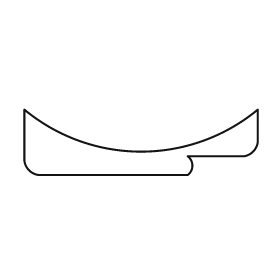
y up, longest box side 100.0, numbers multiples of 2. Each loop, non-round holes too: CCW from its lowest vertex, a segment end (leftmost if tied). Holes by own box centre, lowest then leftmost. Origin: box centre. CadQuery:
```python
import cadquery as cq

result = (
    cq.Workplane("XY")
    .moveTo(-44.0, -14.0)
    .lineTo(20.0, -14.0)
    .threePointArc((22.0, -10.0), (20.0, -6.0))
    .lineTo(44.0, -6.0)
    .threePointArc((48.0, -4.0), (50.0, 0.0))
    .lineTo(50.0, 14.0)
    .threePointArc((0.0, -4.0), (-50.0, 14.0))
    .lineTo(-50.0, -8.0)
    .threePointArc((-48.0, -12.0), (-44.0, -14.0))
    .close()
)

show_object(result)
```